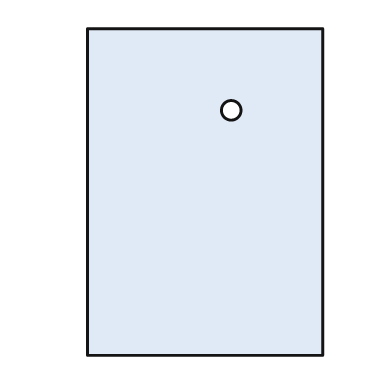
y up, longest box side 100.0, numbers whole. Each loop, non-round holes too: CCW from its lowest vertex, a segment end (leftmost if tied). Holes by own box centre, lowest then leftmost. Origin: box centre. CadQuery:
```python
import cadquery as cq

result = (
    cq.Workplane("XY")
    .moveTo(-36.0, -50.0)
    .lineTo(36.0, -50.0)
    .lineTo(36.0, 50.0)
    .lineTo(-36.0, 50.0)
    .close()
    .moveTo(8.0, 25.0)
    .circle(3.0)
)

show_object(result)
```